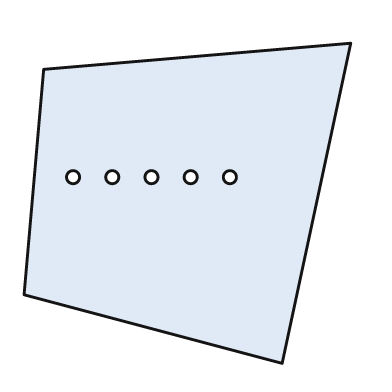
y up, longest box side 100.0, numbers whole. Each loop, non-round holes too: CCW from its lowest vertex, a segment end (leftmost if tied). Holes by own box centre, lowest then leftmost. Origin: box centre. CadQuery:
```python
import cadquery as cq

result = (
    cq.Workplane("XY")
    .moveTo(29.0, -49.0)
    .lineTo(50.0, 49.0)
    .lineTo(-44.0, 41.0)
    .lineTo(-50.0, -28.0)
    .close()
    .moveTo(-35.0, 8.0)
    .circle(2.0)
    .moveTo(-23.0, 8.0)
    .circle(2.0)
    .moveTo(-11.0, 8.0)
    .circle(2.0)
    .moveTo(1.0, 8.0)
    .circle(2.0)
    .moveTo(13.0, 8.0)
    .circle(2.0)
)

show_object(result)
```